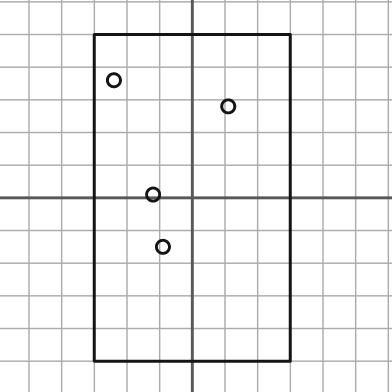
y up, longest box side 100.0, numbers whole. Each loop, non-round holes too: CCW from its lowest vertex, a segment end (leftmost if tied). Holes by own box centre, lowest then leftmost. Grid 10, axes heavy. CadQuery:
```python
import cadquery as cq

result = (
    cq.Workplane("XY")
    .moveTo(-30.0, -50.0)
    .lineTo(30.0, -50.0)
    .lineTo(30.0, 50.0)
    .lineTo(-30.0, 50.0)
    .close()
    .moveTo(-9.0, -15.0)
    .circle(2.0)
    .moveTo(-12.0, 1.0)
    .circle(2.0)
    .moveTo(11.0, 28.0)
    .circle(2.0)
    .moveTo(-24.0, 36.0)
    .circle(2.0)
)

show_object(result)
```